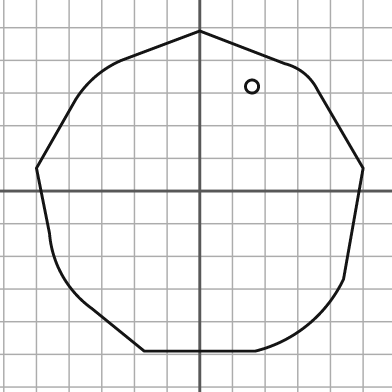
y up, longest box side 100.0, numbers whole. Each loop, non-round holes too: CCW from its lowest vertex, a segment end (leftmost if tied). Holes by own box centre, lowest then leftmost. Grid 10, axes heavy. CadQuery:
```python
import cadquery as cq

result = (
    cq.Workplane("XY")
    .moveTo(-17.0, -49.0)
    .lineTo(17.0, -49.0)
    .threePointArc((33.0, -41.0), (44.0, -27.0))
    .lineTo(50.0, 7.0)
    .lineTo(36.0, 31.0)
    .threePointArc((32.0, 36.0), (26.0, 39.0))
    .lineTo(0.0, 49.0)
    .lineTo(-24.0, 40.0)
    .threePointArc((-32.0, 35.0), (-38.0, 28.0))
    .lineTo(-50.0, 7.0)
    .lineTo(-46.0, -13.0)
    .threePointArc((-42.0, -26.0), (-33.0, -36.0))
    .close()
    .moveTo(16.0, 32.0)
    .circle(2.0)
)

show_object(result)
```